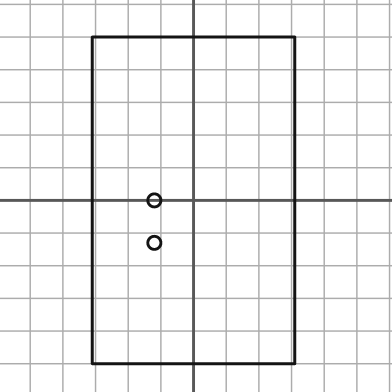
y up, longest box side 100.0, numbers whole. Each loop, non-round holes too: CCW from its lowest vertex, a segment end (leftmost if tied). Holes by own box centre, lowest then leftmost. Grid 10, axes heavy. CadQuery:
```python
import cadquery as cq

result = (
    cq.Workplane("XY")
    .moveTo(-31.0, -50.0)
    .lineTo(31.0, -50.0)
    .lineTo(31.0, 50.0)
    .lineTo(-31.0, 50.0)
    .close()
    .moveTo(-12.0, -13.0)
    .circle(2.0)
    .moveTo(-12.0, 0.0)
    .circle(2.0)
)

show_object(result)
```